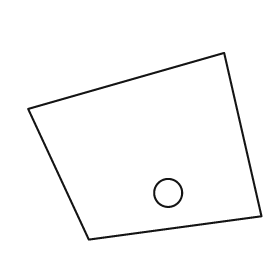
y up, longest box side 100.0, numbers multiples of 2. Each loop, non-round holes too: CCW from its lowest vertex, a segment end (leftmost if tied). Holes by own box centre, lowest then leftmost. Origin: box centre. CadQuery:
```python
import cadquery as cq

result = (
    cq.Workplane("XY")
    .moveTo(-24.0, -40.0)
    .lineTo(50.0, -30.0)
    .lineTo(34.0, 40.0)
    .lineTo(-50.0, 16.0)
    .close()
    .moveTo(10.0, -20.0)
    .circle(6.0)
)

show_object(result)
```